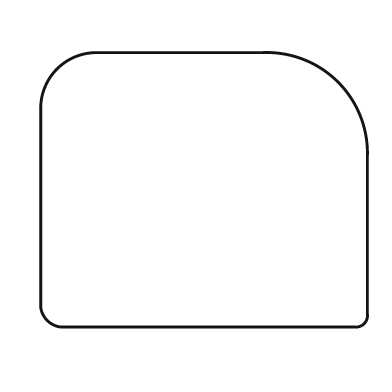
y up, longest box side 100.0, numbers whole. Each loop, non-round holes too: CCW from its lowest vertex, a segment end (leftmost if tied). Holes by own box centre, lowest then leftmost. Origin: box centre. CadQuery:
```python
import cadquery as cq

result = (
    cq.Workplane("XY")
    .moveTo(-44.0, -42.0)
    .lineTo(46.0, -42.0)
    .threePointArc((49.0, -41.0), (50.0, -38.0))
    .lineTo(50.0, 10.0)
    .threePointArc((41.0, 33.0), (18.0, 42.0))
    .lineTo(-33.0, 42.0)
    .threePointArc((-45.0, 37.0), (-50.0, 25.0))
    .lineTo(-50.0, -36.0)
    .threePointArc((-48.0, -40.0), (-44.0, -42.0))
    .close()
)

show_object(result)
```